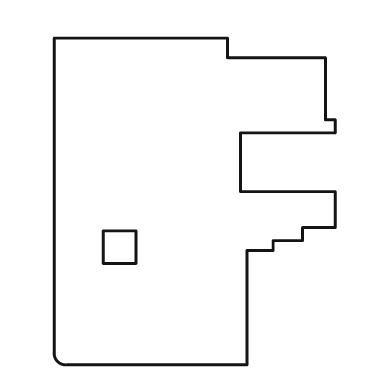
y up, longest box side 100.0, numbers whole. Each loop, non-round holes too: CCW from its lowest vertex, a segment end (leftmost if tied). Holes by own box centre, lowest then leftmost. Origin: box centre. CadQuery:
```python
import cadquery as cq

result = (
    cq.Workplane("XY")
    .moveTo(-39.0, -50.0)
    .lineTo(16.0, -50.0)
    .lineTo(16.0, -15.0)
    .lineTo(24.0, -15.0)
    .lineTo(24.0, -12.0)
    .lineTo(33.0, -12.0)
    .lineTo(33.0, -8.0)
    .lineTo(43.0, -8.0)
    .lineTo(43.0, 3.0)
    .lineTo(14.0, 3.0)
    .lineTo(14.0, 21.0)
    .lineTo(43.0, 21.0)
    .lineTo(43.0, 25.0)
    .lineTo(40.0, 25.0)
    .lineTo(40.0, 44.0)
    .lineTo(10.0, 44.0)
    .lineTo(10.0, 50.0)
    .lineTo(-43.0, 50.0)
    .lineTo(-43.0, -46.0)
    .threePointArc((-42.0, -49.0), (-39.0, -50.0))
    .close()
    .moveTo(-28.0, -19.0)
    .lineTo(-18.0, -19.0)
    .lineTo(-18.0, -9.0)
    .lineTo(-28.0, -9.0)
    .close()
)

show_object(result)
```